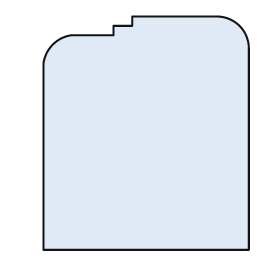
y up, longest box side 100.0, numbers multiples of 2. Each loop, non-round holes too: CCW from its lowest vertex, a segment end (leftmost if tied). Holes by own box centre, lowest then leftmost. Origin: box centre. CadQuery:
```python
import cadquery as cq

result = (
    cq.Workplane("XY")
    .moveTo(-44.0, -50.0)
    .lineTo(44.0, -50.0)
    .lineTo(44.0, 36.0)
    .threePointArc((40.0, 46.0), (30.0, 50.0))
    .lineTo(-6.0, 50.0)
    .lineTo(-6.0, 46.0)
    .lineTo(-14.0, 46.0)
    .lineTo(-14.0, 42.0)
    .lineTo(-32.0, 42.0)
    .threePointArc((-40.0, 38.0), (-44.0, 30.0))
    .close()
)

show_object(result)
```